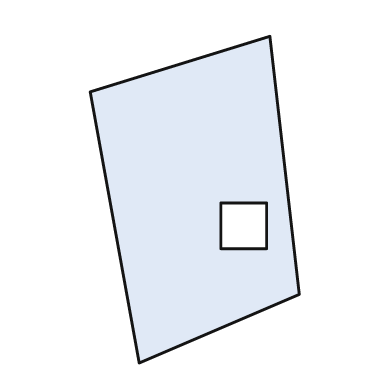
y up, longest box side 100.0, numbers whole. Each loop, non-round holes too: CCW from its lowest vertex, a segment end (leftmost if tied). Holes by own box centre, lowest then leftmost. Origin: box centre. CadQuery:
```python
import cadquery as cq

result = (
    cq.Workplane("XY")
    .moveTo(-17.0, -50.0)
    .lineTo(32.0, -29.0)
    .lineTo(23.0, 50.0)
    .lineTo(-32.0, 33.0)
    .close()
    .moveTo(8.0, -15.0)
    .lineTo(22.0, -15.0)
    .lineTo(22.0, -1.0)
    .lineTo(8.0, -1.0)
    .close()
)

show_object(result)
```